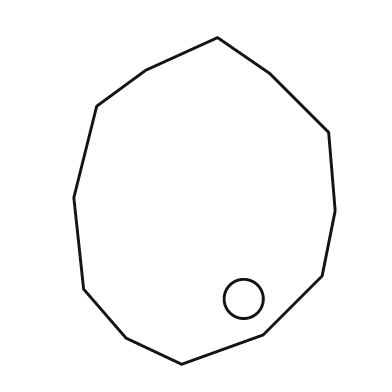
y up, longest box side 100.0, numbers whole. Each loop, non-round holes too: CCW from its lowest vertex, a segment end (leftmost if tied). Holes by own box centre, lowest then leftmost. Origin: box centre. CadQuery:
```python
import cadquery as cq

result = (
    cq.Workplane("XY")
    .moveTo(-7.0, -50.0)
    .lineTo(18.0, -41.0)
    .lineTo(36.0, -23.0)
    .lineTo(40.0, -3.0)
    .lineTo(38.0, 21.0)
    .lineTo(20.0, 39.0)
    .lineTo(4.0, 50.0)
    .lineTo(-18.0, 40.0)
    .lineTo(-33.0, 29.0)
    .lineTo(-40.0, 1.0)
    .lineTo(-37.0, -27.0)
    .lineTo(-24.0, -42.0)
    .close()
    .moveTo(12.0, -30.0)
    .circle(6.0)
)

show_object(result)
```